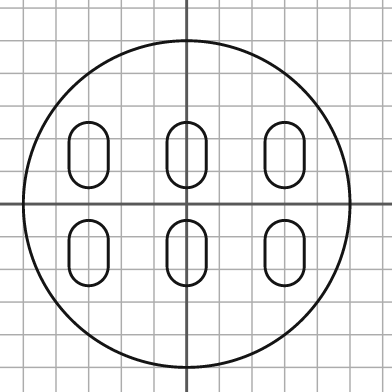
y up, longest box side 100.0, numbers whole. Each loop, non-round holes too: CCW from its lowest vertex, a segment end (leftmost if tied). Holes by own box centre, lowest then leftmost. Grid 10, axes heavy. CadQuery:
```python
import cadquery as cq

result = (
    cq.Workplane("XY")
    .moveTo(0.0, 0.0)
    .circle(50.0)
    .moveTo(-36.0, -19.0)
    .threePointArc((-30.0, -25.0), (-24.0, -19.0))
    .lineTo(-24.0, -11.0)
    .threePointArc((-30.0, -5.0), (-36.0, -11.0))
    .close()
    .moveTo(-6.0, -19.0)
    .threePointArc((0.0, -25.0), (6.0, -19.0))
    .lineTo(6.0, -11.0)
    .threePointArc((0.0, -5.0), (-6.0, -11.0))
    .close()
    .moveTo(24.0, -19.0)
    .threePointArc((30.0, -25.0), (36.0, -19.0))
    .lineTo(36.0, -11.0)
    .threePointArc((30.0, -5.0), (24.0, -11.0))
    .close()
    .moveTo(-36.0, 11.0)
    .threePointArc((-30.0, 5.0), (-24.0, 11.0))
    .lineTo(-24.0, 19.0)
    .threePointArc((-30.0, 25.0), (-36.0, 19.0))
    .close()
    .moveTo(-6.0, 11.0)
    .threePointArc((0.0, 5.0), (6.0, 11.0))
    .lineTo(6.0, 19.0)
    .threePointArc((0.0, 25.0), (-6.0, 19.0))
    .close()
    .moveTo(24.0, 11.0)
    .threePointArc((30.0, 5.0), (36.0, 11.0))
    .lineTo(36.0, 19.0)
    .threePointArc((30.0, 25.0), (24.0, 19.0))
    .close()
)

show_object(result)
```